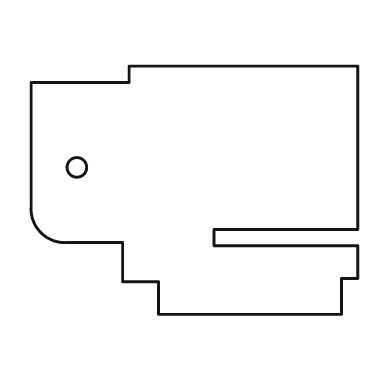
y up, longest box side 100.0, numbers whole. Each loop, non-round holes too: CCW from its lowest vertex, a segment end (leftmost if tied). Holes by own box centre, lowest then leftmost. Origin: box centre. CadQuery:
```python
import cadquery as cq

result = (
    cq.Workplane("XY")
    .moveTo(-11.0, -38.0)
    .lineTo(45.0, -38.0)
    .lineTo(45.0, -27.0)
    .lineTo(50.0, -27.0)
    .lineTo(50.0, -17.0)
    .lineTo(6.0, -17.0)
    .lineTo(6.0, -12.0)
    .lineTo(50.0, -12.0)
    .lineTo(50.0, 38.0)
    .lineTo(-20.0, 38.0)
    .lineTo(-20.0, 33.0)
    .lineTo(-50.0, 33.0)
    .lineTo(-50.0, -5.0)
    .threePointArc((-47.0, -13.0), (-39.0, -16.0))
    .lineTo(-22.0, -16.0)
    .lineTo(-22.0, -28.0)
    .lineTo(-11.0, -28.0)
    .close()
    .moveTo(-36.0, 7.0)
    .circle(3.0)
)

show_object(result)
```